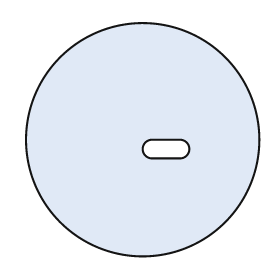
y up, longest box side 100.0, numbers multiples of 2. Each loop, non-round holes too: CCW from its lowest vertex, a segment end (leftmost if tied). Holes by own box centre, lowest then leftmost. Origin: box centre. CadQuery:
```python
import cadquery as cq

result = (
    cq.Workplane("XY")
    .moveTo(0.0, 0.0)
    .circle(50.0)
    .moveTo(4.0, -8.0)
    .lineTo(16.0, -8.0)
    .threePointArc((20.0, -4.0), (16.0, 0.0))
    .lineTo(4.0, 0.0)
    .threePointArc((0.0, -4.0), (4.0, -8.0))
    .close()
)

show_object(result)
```